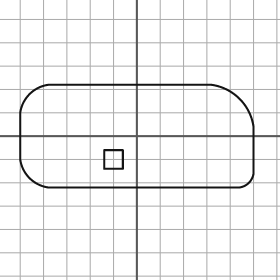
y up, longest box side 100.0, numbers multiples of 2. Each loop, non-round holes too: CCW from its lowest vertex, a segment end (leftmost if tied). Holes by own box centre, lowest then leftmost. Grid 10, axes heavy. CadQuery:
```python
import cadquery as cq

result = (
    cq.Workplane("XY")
    .moveTo(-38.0, -22.0)
    .lineTo(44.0, -22.0)
    .threePointArc((48.0, -20.0), (50.0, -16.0))
    .lineTo(50.0, 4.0)
    .threePointArc((44.0, 16.0), (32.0, 22.0))
    .lineTo(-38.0, 22.0)
    .threePointArc((-46.0, 18.0), (-50.0, 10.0))
    .lineTo(-50.0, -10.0)
    .threePointArc((-46.0, -18.0), (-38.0, -22.0))
    .close()
    .moveTo(-14.0, -14.0)
    .lineTo(-6.0, -14.0)
    .lineTo(-6.0, -6.0)
    .lineTo(-14.0, -6.0)
    .close()
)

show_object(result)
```